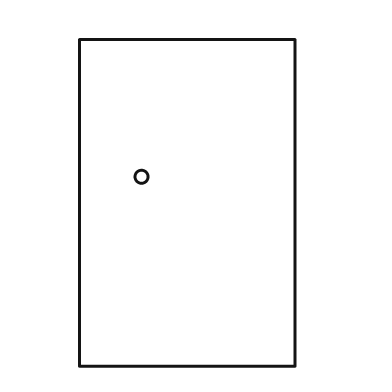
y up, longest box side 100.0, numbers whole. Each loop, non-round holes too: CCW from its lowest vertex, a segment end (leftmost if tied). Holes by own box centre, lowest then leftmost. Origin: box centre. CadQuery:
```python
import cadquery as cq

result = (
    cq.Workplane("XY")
    .moveTo(-33.0, -50.0)
    .lineTo(33.0, -50.0)
    .lineTo(33.0, 50.0)
    .lineTo(-33.0, 50.0)
    .close()
    .moveTo(-14.0, 8.0)
    .circle(2.0)
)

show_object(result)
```